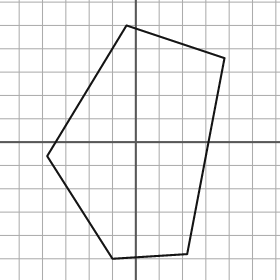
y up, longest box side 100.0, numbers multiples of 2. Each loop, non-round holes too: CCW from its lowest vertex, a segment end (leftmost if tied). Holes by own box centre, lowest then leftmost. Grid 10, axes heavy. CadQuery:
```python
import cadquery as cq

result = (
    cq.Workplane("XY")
    .moveTo(-10.0, -50.0)
    .lineTo(22.0, -48.0)
    .lineTo(38.0, 36.0)
    .lineTo(-4.0, 50.0)
    .lineTo(-38.0, -6.0)
    .close()
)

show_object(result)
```